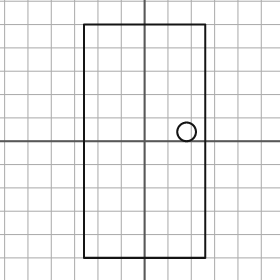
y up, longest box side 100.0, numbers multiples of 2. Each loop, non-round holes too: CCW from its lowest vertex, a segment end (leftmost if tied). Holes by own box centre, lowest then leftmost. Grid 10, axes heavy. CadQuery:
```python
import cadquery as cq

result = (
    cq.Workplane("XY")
    .moveTo(-26.0, -50.0)
    .lineTo(26.0, -50.0)
    .lineTo(26.0, 50.0)
    .lineTo(-26.0, 50.0)
    .close()
    .moveTo(18.0, 4.0)
    .circle(4.0)
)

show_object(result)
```